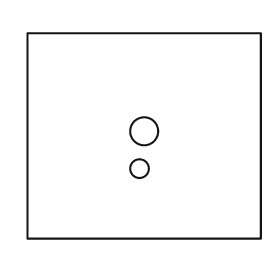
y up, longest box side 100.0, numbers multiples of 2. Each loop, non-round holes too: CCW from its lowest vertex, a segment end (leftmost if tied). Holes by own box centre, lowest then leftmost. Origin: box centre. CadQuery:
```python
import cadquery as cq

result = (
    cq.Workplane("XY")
    .moveTo(-50.0, -44.0)
    .lineTo(50.0, -44.0)
    .lineTo(50.0, 44.0)
    .lineTo(-50.0, 44.0)
    .close()
    .moveTo(-2.0, -14.0)
    .circle(4.0)
    .moveTo(0.0, 2.0)
    .circle(6.0)
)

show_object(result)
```